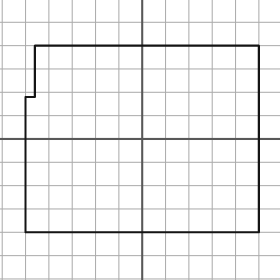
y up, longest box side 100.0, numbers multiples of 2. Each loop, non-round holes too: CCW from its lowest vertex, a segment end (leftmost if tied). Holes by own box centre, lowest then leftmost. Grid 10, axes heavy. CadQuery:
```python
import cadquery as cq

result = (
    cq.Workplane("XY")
    .moveTo(-50.0, -40.0)
    .lineTo(50.0, -40.0)
    .lineTo(50.0, 40.0)
    .lineTo(-46.0, 40.0)
    .lineTo(-46.0, 18.0)
    .lineTo(-50.0, 18.0)
    .close()
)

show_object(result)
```